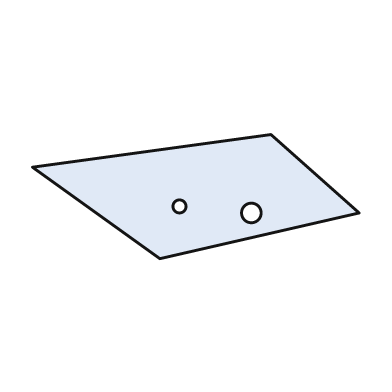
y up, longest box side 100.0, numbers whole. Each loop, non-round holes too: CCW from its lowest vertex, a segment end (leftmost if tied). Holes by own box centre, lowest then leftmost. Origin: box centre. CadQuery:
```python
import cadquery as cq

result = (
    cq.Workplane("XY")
    .moveTo(-11.0, -19.0)
    .lineTo(50.0, -5.0)
    .lineTo(23.0, 19.0)
    .lineTo(-50.0, 9.0)
    .close()
    .moveTo(17.0, -5.0)
    .circle(3.0)
    .moveTo(-5.0, -3.0)
    .circle(2.0)
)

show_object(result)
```